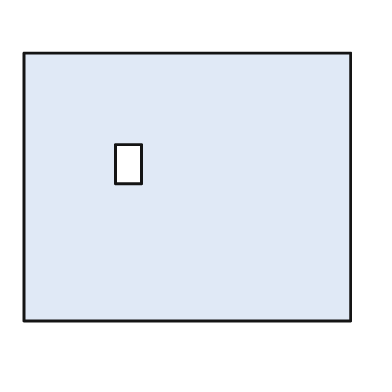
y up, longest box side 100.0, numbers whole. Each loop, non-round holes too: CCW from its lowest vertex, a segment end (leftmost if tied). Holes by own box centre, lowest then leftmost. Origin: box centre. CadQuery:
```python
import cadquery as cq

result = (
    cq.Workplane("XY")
    .moveTo(-50.0, -41.0)
    .lineTo(50.0, -41.0)
    .lineTo(50.0, 41.0)
    .lineTo(-50.0, 41.0)
    .close()
    .moveTo(-22.0, 1.0)
    .lineTo(-14.0, 1.0)
    .lineTo(-14.0, 13.0)
    .lineTo(-22.0, 13.0)
    .close()
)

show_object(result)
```